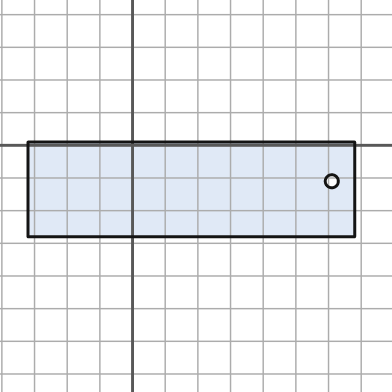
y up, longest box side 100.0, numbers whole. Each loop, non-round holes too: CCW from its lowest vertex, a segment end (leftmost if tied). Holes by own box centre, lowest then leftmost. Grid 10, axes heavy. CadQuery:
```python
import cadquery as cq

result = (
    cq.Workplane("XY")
    .moveTo(-32.0, -28.0)
    .lineTo(68.0, -28.0)
    .lineTo(68.0, 1.0)
    .lineTo(-32.0, 1.0)
    .close()
    .moveTo(61.0, -11.0)
    .circle(2.0)
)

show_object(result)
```